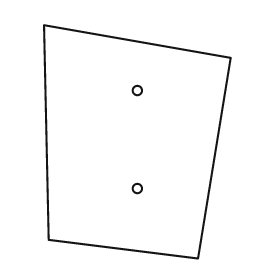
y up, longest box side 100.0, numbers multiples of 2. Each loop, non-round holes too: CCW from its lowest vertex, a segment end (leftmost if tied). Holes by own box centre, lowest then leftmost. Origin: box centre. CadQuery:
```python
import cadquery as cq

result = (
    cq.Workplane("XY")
    .moveTo(26.0, -50.0)
    .lineTo(40.0, 36.0)
    .lineTo(-40.0, 50.0)
    .lineTo(-38.0, -42.0)
    .close()
    .moveTo(0.0, -20.0)
    .circle(2.0)
    .moveTo(0.0, 22.0)
    .circle(2.0)
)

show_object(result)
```